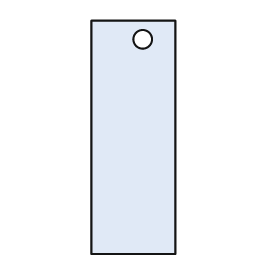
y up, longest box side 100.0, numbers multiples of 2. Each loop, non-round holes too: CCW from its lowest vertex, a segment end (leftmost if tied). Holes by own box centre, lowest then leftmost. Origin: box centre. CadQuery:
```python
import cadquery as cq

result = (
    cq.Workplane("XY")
    .moveTo(-18.0, -50.0)
    .lineTo(18.0, -50.0)
    .lineTo(18.0, 50.0)
    .lineTo(-18.0, 50.0)
    .close()
    .moveTo(4.0, 42.0)
    .circle(4.0)
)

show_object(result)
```